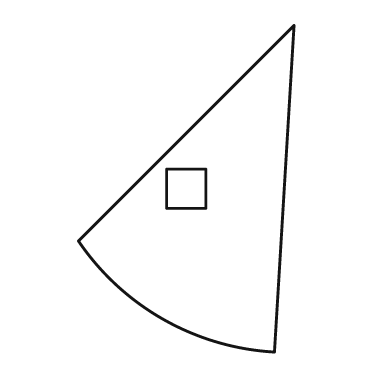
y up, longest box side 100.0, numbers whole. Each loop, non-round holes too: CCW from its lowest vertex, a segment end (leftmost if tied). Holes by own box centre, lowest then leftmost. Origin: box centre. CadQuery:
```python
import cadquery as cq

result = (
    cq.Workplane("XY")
    .moveTo(27.0, -50.0)
    .lineTo(33.0, 50.0)
    .lineTo(-33.0, -16.0)
    .threePointArc((-7.0, -40.0), (27.0, -50.0))
    .close()
    .moveTo(-6.0, -6.0)
    .lineTo(6.0, -6.0)
    .lineTo(6.0, 6.0)
    .lineTo(-6.0, 6.0)
    .close()
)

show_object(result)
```